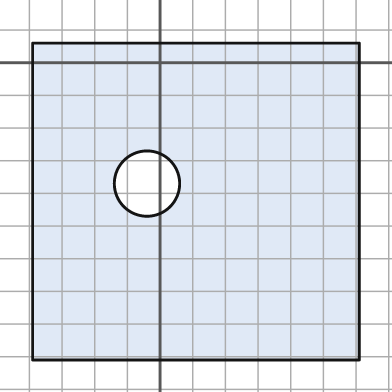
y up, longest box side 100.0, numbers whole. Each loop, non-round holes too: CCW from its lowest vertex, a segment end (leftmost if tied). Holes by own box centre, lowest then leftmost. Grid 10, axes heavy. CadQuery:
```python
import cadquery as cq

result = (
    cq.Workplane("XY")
    .moveTo(-39.0, -91.0)
    .lineTo(61.0, -91.0)
    .lineTo(61.0, 6.0)
    .lineTo(-39.0, 6.0)
    .close()
    .moveTo(-4.0, -37.0)
    .circle(10.0)
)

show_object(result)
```